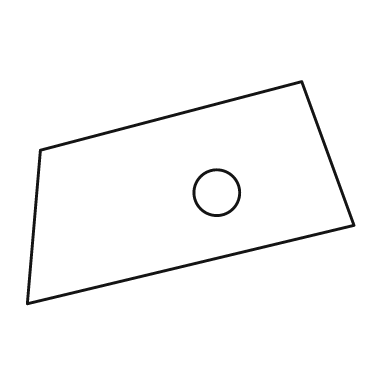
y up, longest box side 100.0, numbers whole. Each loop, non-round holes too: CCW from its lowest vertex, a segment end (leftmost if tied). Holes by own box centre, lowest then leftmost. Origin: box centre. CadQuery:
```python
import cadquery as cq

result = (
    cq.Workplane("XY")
    .moveTo(-50.0, -34.0)
    .lineTo(50.0, -10.0)
    .lineTo(34.0, 34.0)
    .lineTo(-46.0, 13.0)
    .close()
    .moveTo(8.0, 0.0)
    .circle(7.0)
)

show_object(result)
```